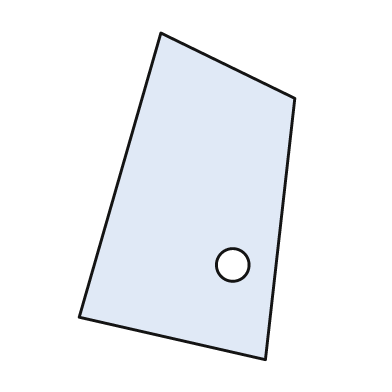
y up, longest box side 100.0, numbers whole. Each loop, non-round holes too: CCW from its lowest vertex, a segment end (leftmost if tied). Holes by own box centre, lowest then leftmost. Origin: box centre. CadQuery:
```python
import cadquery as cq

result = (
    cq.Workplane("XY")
    .moveTo(24.0, -50.0)
    .lineTo(33.0, 30.0)
    .lineTo(-8.0, 50.0)
    .lineTo(-33.0, -37.0)
    .close()
    .moveTo(14.0, -21.0)
    .circle(5.0)
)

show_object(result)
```